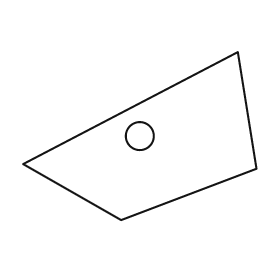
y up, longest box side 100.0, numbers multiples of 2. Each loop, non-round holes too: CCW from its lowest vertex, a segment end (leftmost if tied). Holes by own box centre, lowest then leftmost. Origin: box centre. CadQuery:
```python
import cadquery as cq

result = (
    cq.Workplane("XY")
    .moveTo(-8.0, -36.0)
    .lineTo(50.0, -14.0)
    .lineTo(42.0, 36.0)
    .lineTo(-50.0, -12.0)
    .close()
    .moveTo(0.0, 0.0)
    .circle(6.0)
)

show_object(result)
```